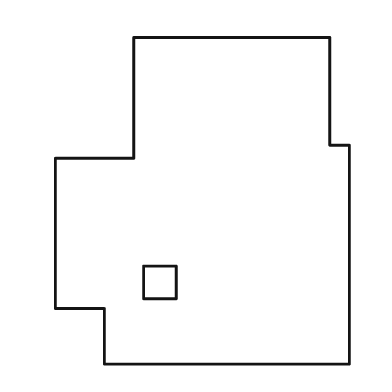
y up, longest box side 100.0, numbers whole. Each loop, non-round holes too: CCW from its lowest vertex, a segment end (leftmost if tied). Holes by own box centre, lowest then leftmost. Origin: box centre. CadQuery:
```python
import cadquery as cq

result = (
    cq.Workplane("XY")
    .moveTo(-30.0, -50.0)
    .lineTo(45.0, -50.0)
    .lineTo(45.0, 17.0)
    .lineTo(39.0, 17.0)
    .lineTo(39.0, 50.0)
    .lineTo(-21.0, 50.0)
    .lineTo(-21.0, 13.0)
    .lineTo(-45.0, 13.0)
    .lineTo(-45.0, -33.0)
    .lineTo(-30.0, -33.0)
    .close()
    .moveTo(-18.0, -30.0)
    .lineTo(-8.0, -30.0)
    .lineTo(-8.0, -20.0)
    .lineTo(-18.0, -20.0)
    .close()
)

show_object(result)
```